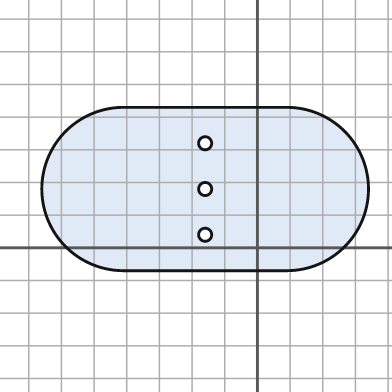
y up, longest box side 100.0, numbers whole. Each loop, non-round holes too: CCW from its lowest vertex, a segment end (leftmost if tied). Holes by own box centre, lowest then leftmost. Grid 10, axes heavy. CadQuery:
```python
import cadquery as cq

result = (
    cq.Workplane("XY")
    .moveTo(-41.0, -7.0)
    .lineTo(9.0, -7.0)
    .threePointArc((34.0, 18.0), (9.0, 43.0))
    .lineTo(-41.0, 43.0)
    .threePointArc((-66.0, 18.0), (-41.0, -7.0))
    .close()
    .moveTo(-16.0, 4.0)
    .circle(2.0)
    .moveTo(-16.0, 18.0)
    .circle(2.0)
    .moveTo(-16.0, 32.0)
    .circle(2.0)
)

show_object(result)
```